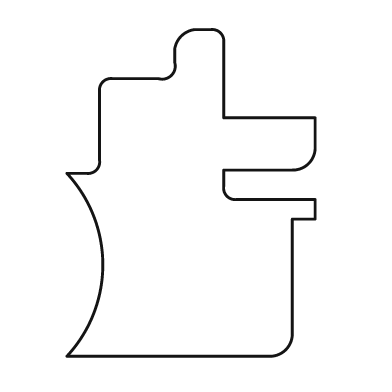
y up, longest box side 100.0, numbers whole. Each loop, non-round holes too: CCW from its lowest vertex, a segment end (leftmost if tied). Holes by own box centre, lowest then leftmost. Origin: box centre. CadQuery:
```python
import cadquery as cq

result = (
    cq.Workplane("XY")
    .moveTo(-38.0, -50.0)
    .lineTo(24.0, -50.0)
    .threePointArc((29.0, -48.0), (31.0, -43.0))
    .lineTo(31.0, -8.0)
    .lineTo(38.0, -8.0)
    .lineTo(38.0, -2.0)
    .lineTo(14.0, -2.0)
    .threePointArc((11.0, -1.0), (10.0, 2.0))
    .lineTo(10.0, 7.0)
    .lineTo(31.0, 7.0)
    .threePointArc((36.0, 9.0), (38.0, 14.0))
    .lineTo(38.0, 23.0)
    .lineTo(10.0, 23.0)
    .lineTo(10.0, 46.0)
    .threePointArc((9.0, 49.0), (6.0, 50.0))
    .lineTo(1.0, 50.0)
    .threePointArc((-3.0, 48.0), (-5.0, 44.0))
    .lineTo(-5.0, 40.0)
    .threePointArc((-6.0, 36.0), (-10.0, 35.0))
    .lineTo(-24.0, 35.0)
    .threePointArc((-27.0, 34.0), (-28.0, 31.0))
    .lineTo(-28.0, 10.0)
    .threePointArc((-29.0, 7.0), (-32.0, 6.0))
    .lineTo(-38.0, 6.0)
    .threePointArc((-27.0, -22.0), (-38.0, -50.0))
    .close()
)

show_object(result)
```